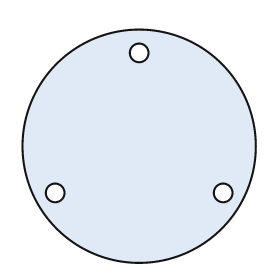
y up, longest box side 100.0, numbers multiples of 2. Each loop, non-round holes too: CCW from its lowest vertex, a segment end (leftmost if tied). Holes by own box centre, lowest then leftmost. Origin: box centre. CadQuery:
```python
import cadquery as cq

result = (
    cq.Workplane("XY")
    .moveTo(0.0, 0.0)
    .circle(50.0)
    .moveTo(-36.0, -20.0)
    .circle(4.0)
    .moveTo(36.0, -20.0)
    .circle(4.0)
    .moveTo(0.0, 40.0)
    .circle(4.0)
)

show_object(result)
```